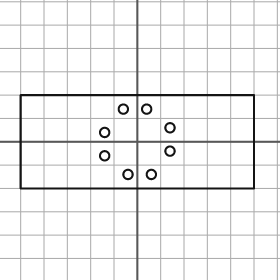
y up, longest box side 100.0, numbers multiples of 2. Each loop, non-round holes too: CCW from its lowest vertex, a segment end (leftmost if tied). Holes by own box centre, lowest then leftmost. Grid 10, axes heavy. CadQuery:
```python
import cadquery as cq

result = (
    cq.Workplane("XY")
    .moveTo(-50.0, -20.0)
    .lineTo(50.0, -20.0)
    .lineTo(50.0, 20.0)
    .lineTo(-50.0, 20.0)
    .close()
    .moveTo(-4.0, -14.0)
    .circle(2.0)
    .moveTo(6.0, -14.0)
    .circle(2.0)
    .moveTo(-14.0, -6.0)
    .circle(2.0)
    .moveTo(14.0, -4.0)
    .circle(2.0)
    .moveTo(-14.0, 4.0)
    .circle(2.0)
    .moveTo(14.0, 6.0)
    .circle(2.0)
    .moveTo(-6.0, 14.0)
    .circle(2.0)
    .moveTo(4.0, 14.0)
    .circle(2.0)
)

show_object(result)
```